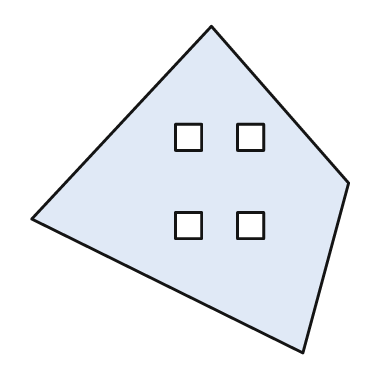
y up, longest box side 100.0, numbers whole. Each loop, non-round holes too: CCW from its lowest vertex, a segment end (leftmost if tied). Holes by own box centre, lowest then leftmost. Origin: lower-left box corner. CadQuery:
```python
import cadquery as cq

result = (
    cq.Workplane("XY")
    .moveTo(83.0, 0.0)
    .lineTo(97.0, 52.0)
    .lineTo(55.0, 100.0)
    .lineTo(0.0, 41.0)
    .close()
    .moveTo(44.0, 35.0)
    .lineTo(52.0, 35.0)
    .lineTo(52.0, 43.0)
    .lineTo(44.0, 43.0)
    .close()
    .moveTo(63.0, 35.0)
    .lineTo(71.0, 35.0)
    .lineTo(71.0, 43.0)
    .lineTo(63.0, 43.0)
    .close()
    .moveTo(44.0, 62.0)
    .lineTo(52.0, 62.0)
    .lineTo(52.0, 70.0)
    .lineTo(44.0, 70.0)
    .close()
    .moveTo(63.0, 62.0)
    .lineTo(71.0, 62.0)
    .lineTo(71.0, 70.0)
    .lineTo(63.0, 70.0)
    .close()
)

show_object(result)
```